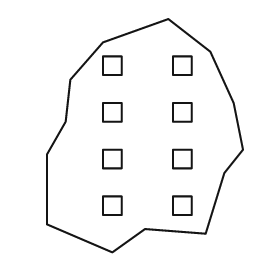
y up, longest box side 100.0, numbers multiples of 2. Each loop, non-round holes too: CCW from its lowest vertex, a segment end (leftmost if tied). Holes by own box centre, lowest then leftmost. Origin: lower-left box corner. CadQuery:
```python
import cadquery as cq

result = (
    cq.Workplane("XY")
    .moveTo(28.0, 0.0)
    .lineTo(42.0, 10.0)
    .lineTo(68.0, 8.0)
    .lineTo(76.0, 34.0)
    .lineTo(84.0, 44.0)
    .lineTo(80.0, 64.0)
    .lineTo(70.0, 86.0)
    .lineTo(52.0, 100.0)
    .lineTo(24.0, 90.0)
    .lineTo(10.0, 74.0)
    .lineTo(8.0, 56.0)
    .lineTo(0.0, 42.0)
    .lineTo(0.0, 12.0)
    .close()
    .moveTo(24.0, 16.0)
    .lineTo(32.0, 16.0)
    .lineTo(32.0, 24.0)
    .lineTo(24.0, 24.0)
    .close()
    .moveTo(54.0, 16.0)
    .lineTo(62.0, 16.0)
    .lineTo(62.0, 24.0)
    .lineTo(54.0, 24.0)
    .close()
    .moveTo(24.0, 36.0)
    .lineTo(32.0, 36.0)
    .lineTo(32.0, 44.0)
    .lineTo(24.0, 44.0)
    .close()
    .moveTo(54.0, 36.0)
    .lineTo(62.0, 36.0)
    .lineTo(62.0, 44.0)
    .lineTo(54.0, 44.0)
    .close()
    .moveTo(24.0, 56.0)
    .lineTo(32.0, 56.0)
    .lineTo(32.0, 64.0)
    .lineTo(24.0, 64.0)
    .close()
    .moveTo(54.0, 56.0)
    .lineTo(62.0, 56.0)
    .lineTo(62.0, 64.0)
    .lineTo(54.0, 64.0)
    .close()
    .moveTo(24.0, 76.0)
    .lineTo(32.0, 76.0)
    .lineTo(32.0, 84.0)
    .lineTo(24.0, 84.0)
    .close()
    .moveTo(54.0, 76.0)
    .lineTo(62.0, 76.0)
    .lineTo(62.0, 84.0)
    .lineTo(54.0, 84.0)
    .close()
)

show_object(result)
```